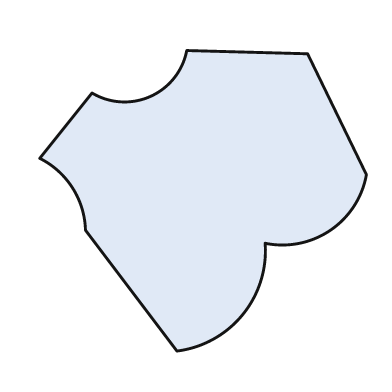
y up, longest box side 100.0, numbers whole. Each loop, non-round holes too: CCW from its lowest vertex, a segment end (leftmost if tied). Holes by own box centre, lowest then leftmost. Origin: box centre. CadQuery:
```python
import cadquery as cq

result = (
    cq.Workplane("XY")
    .moveTo(-8.0, -46.0)
    .threePointArc((12.0, -35.0), (19.0, -13.0))
    .threePointArc((39.0, -9.0), (50.0, 8.0))
    .lineTo(32.0, 45.0)
    .lineTo(-5.0, 46.0)
    .threePointArc((-16.0, 32.0), (-34.0, 33.0))
    .lineTo(-50.0, 13.0)
    .threePointArc((-40.0, 4.0), (-36.0, -9.0))
    .close()
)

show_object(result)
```